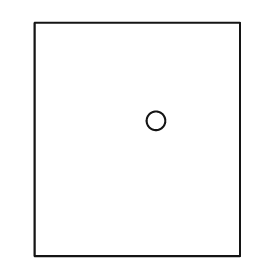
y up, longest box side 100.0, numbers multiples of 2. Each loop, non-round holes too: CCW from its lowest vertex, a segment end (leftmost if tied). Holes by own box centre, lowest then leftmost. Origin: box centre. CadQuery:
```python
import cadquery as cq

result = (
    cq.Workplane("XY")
    .moveTo(-44.0, -50.0)
    .lineTo(44.0, -50.0)
    .lineTo(44.0, 50.0)
    .lineTo(-44.0, 50.0)
    .close()
    .moveTo(8.0, 8.0)
    .circle(4.0)
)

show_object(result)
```